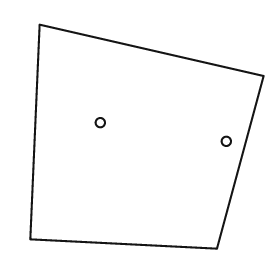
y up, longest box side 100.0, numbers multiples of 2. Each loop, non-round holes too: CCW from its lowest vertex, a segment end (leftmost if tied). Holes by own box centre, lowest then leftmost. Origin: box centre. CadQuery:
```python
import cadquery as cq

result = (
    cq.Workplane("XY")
    .moveTo(30.0, -48.0)
    .lineTo(50.0, 26.0)
    .lineTo(-46.0, 48.0)
    .lineTo(-50.0, -44.0)
    .close()
    .moveTo(34.0, -2.0)
    .circle(2.0)
    .moveTo(-20.0, 6.0)
    .circle(2.0)
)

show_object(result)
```